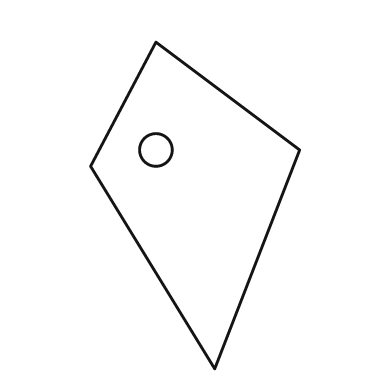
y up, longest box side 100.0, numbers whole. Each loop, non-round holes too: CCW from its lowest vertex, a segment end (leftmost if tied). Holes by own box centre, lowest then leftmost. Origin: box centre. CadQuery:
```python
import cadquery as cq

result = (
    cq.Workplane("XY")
    .moveTo(6.0, -50.0)
    .lineTo(32.0, 17.0)
    .lineTo(-12.0, 50.0)
    .lineTo(-32.0, 12.0)
    .close()
    .moveTo(-12.0, 17.0)
    .circle(5.0)
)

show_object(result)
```